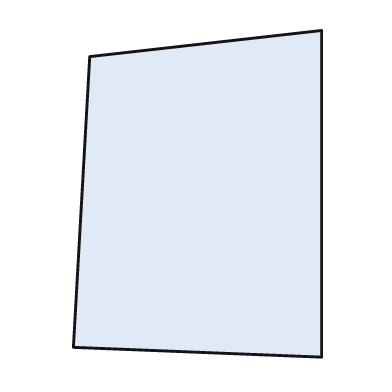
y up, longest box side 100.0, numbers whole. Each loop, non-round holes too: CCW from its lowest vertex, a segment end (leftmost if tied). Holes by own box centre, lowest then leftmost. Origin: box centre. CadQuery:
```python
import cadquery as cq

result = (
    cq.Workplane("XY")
    .moveTo(38.0, -50.0)
    .lineTo(38.0, 50.0)
    .lineTo(-33.0, 42.0)
    .lineTo(-38.0, -47.0)
    .close()
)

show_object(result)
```